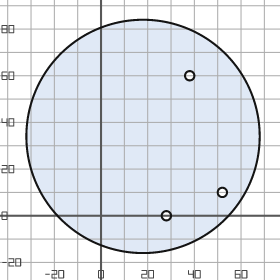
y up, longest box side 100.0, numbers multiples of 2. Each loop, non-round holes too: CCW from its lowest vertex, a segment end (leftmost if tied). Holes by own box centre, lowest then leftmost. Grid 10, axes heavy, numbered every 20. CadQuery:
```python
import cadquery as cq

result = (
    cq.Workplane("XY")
    .moveTo(18.0, 34.0)
    .circle(50.0)
    .moveTo(28.0, 0.0)
    .circle(2.0)
    .moveTo(52.0, 10.0)
    .circle(2.0)
    .moveTo(38.0, 60.0)
    .circle(2.0)
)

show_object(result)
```